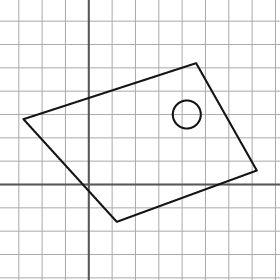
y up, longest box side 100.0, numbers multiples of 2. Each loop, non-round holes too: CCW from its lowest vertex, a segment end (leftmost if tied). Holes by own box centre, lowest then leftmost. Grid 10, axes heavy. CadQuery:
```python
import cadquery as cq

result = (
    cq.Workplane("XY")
    .moveTo(12.0, -16.0)
    .lineTo(72.0, 6.0)
    .lineTo(46.0, 52.0)
    .lineTo(-28.0, 28.0)
    .close()
    .moveTo(42.0, 30.0)
    .circle(6.0)
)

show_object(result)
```